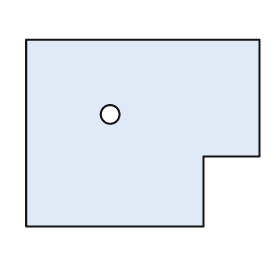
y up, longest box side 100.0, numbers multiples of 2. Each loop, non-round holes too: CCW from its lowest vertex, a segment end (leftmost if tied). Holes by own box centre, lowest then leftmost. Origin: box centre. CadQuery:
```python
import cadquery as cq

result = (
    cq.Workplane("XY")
    .moveTo(-50.0, -40.0)
    .lineTo(26.0, -40.0)
    .lineTo(26.0, -10.0)
    .lineTo(50.0, -10.0)
    .lineTo(50.0, 40.0)
    .lineTo(-50.0, 40.0)
    .close()
    .moveTo(-14.0, 8.0)
    .circle(4.0)
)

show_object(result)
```